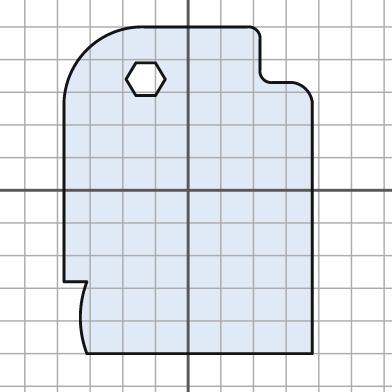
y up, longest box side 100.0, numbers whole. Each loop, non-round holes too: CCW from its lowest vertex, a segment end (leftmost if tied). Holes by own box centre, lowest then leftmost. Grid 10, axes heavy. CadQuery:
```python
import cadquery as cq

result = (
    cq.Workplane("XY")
    .moveTo(-31.0, -50.0)
    .lineTo(38.0, -50.0)
    .lineTo(38.0, 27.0)
    .threePointArc((36.0, 31.0), (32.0, 33.0))
    .lineTo(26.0, 33.0)
    .threePointArc((23.0, 34.0), (22.0, 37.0))
    .lineTo(22.0, 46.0)
    .threePointArc((21.0, 49.0), (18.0, 50.0))
    .lineTo(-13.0, 50.0)
    .threePointArc((-31.0, 43.0), (-38.0, 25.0))
    .lineTo(-38.0, -28.0)
    .lineTo(-31.0, -28.0)
    .threePointArc((-33.0, -39.0), (-31.0, -50.0))
    .close()
    .moveTo(-16.0, 29.0)
    .lineTo(-10.0, 29.0)
    .lineTo(-7.0, 34.0)
    .lineTo(-10.0, 39.0)
    .lineTo(-16.0, 39.0)
    .lineTo(-19.0, 34.0)
    .close()
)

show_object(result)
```